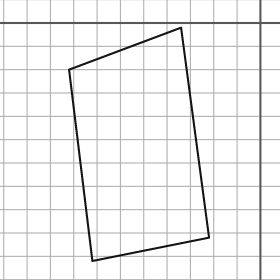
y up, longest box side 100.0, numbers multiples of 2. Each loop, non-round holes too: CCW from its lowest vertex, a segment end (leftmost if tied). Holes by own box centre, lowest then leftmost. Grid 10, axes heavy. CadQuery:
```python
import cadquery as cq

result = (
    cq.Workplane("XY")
    .moveTo(-72.0, -102.0)
    .lineTo(-22.0, -92.0)
    .lineTo(-34.0, -2.0)
    .lineTo(-82.0, -20.0)
    .close()
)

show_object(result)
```